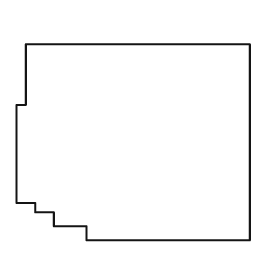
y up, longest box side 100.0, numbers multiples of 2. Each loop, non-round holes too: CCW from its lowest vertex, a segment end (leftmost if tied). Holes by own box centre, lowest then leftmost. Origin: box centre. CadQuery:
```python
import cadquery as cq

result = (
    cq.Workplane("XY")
    .moveTo(-20.0, -42.0)
    .lineTo(50.0, -42.0)
    .lineTo(50.0, 42.0)
    .lineTo(-46.0, 42.0)
    .lineTo(-46.0, 16.0)
    .lineTo(-50.0, 16.0)
    .lineTo(-50.0, -26.0)
    .lineTo(-42.0, -26.0)
    .lineTo(-42.0, -30.0)
    .lineTo(-34.0, -30.0)
    .lineTo(-34.0, -36.0)
    .lineTo(-20.0, -36.0)
    .close()
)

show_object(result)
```